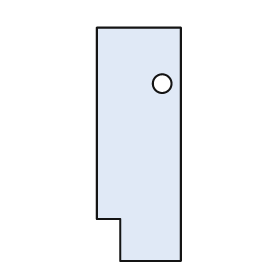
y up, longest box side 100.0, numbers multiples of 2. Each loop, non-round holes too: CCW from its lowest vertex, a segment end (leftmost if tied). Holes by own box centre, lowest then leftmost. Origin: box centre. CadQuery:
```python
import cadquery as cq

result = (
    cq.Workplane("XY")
    .moveTo(-8.0, -50.0)
    .lineTo(18.0, -50.0)
    .lineTo(18.0, 50.0)
    .lineTo(-18.0, 50.0)
    .lineTo(-18.0, -32.0)
    .lineTo(-8.0, -32.0)
    .close()
    .moveTo(10.0, 26.0)
    .circle(4.0)
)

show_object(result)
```